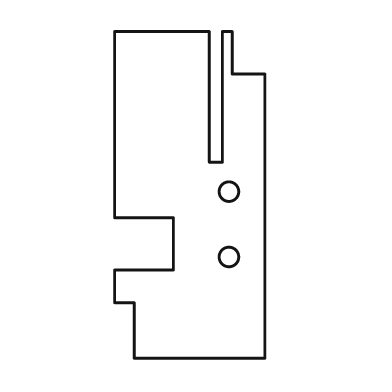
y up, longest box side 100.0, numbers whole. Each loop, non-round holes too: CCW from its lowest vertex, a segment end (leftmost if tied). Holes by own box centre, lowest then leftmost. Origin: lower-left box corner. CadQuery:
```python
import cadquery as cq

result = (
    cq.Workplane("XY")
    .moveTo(6.0, 0.0)
    .lineTo(46.0, 0.0)
    .lineTo(46.0, 87.0)
    .lineTo(36.0, 87.0)
    .lineTo(36.0, 100.0)
    .lineTo(33.0, 100.0)
    .lineTo(33.0, 60.0)
    .lineTo(29.0, 60.0)
    .lineTo(29.0, 100.0)
    .lineTo(0.0, 100.0)
    .lineTo(0.0, 43.0)
    .lineTo(18.0, 43.0)
    .lineTo(18.0, 27.0)
    .lineTo(0.0, 27.0)
    .lineTo(0.0, 17.0)
    .lineTo(6.0, 17.0)
    .close()
    .moveTo(35.0, 31.0)
    .circle(3.0)
    .moveTo(35.0, 51.0)
    .circle(3.0)
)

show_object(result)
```